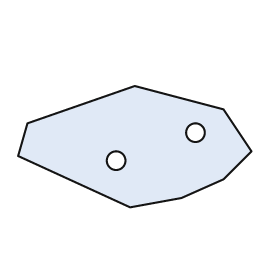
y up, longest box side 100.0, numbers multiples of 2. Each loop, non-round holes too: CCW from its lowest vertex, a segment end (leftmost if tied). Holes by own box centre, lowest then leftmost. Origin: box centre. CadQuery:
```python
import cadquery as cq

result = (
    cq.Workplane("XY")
    .moveTo(-2.0, -26.0)
    .lineTo(20.0, -22.0)
    .lineTo(38.0, -14.0)
    .lineTo(50.0, -2.0)
    .lineTo(38.0, 16.0)
    .lineTo(0.0, 26.0)
    .lineTo(-46.0, 10.0)
    .lineTo(-50.0, -4.0)
    .close()
    .moveTo(-8.0, -6.0)
    .circle(4.0)
    .moveTo(26.0, 6.0)
    .circle(4.0)
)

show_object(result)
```